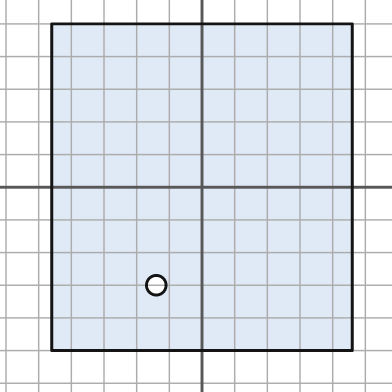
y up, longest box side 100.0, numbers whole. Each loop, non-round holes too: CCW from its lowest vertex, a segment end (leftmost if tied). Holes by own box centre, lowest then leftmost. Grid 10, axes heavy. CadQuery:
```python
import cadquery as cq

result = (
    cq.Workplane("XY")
    .moveTo(-46.0, -50.0)
    .lineTo(46.0, -50.0)
    .lineTo(46.0, 50.0)
    .lineTo(-46.0, 50.0)
    .close()
    .moveTo(-14.0, -30.0)
    .circle(3.0)
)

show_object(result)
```